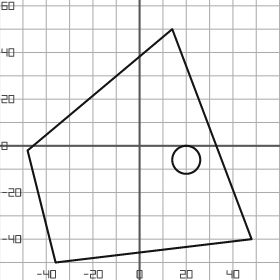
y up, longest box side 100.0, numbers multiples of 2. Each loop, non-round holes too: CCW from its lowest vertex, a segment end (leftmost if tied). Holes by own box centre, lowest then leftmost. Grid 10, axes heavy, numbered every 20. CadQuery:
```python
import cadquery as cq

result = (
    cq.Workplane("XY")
    .moveTo(-36.0, -50.0)
    .lineTo(48.0, -40.0)
    .lineTo(14.0, 50.0)
    .lineTo(-48.0, -2.0)
    .close()
    .moveTo(20.0, -6.0)
    .circle(6.0)
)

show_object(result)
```